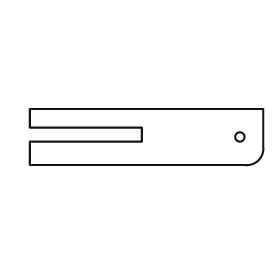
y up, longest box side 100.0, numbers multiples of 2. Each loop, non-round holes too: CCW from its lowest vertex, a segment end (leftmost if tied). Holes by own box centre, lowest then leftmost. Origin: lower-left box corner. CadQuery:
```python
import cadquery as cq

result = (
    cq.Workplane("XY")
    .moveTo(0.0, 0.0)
    .lineTo(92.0, 0.0)
    .threePointArc((98.0, 2.0), (100.0, 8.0))
    .lineTo(100.0, 24.0)
    .lineTo(0.0, 24.0)
    .lineTo(0.0, 16.0)
    .lineTo(48.0, 16.0)
    .lineTo(48.0, 10.0)
    .lineTo(0.0, 10.0)
    .close()
    .moveTo(90.0, 12.0)
    .circle(2.0)
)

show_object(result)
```